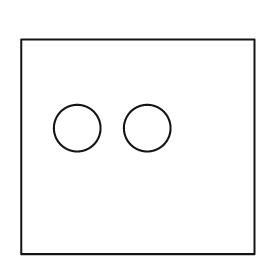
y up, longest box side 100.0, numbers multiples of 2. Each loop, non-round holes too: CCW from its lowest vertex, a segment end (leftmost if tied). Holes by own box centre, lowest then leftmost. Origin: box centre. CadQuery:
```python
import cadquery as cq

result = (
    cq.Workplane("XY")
    .moveTo(-50.0, -46.0)
    .lineTo(50.0, -46.0)
    .lineTo(50.0, 46.0)
    .lineTo(-50.0, 46.0)
    .close()
    .moveTo(-26.0, 8.0)
    .circle(10.0)
    .moveTo(4.0, 8.0)
    .circle(10.0)
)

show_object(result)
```